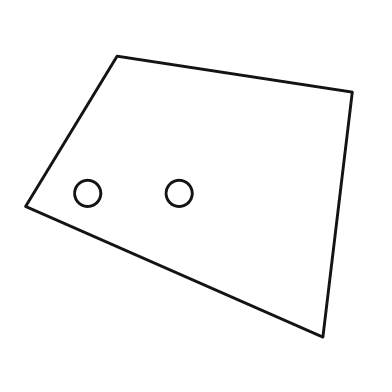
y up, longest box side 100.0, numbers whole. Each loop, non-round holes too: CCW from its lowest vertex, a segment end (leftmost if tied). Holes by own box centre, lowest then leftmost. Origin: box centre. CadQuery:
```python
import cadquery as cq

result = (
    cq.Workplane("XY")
    .moveTo(41.0, -43.0)
    .lineTo(50.0, 32.0)
    .lineTo(-22.0, 43.0)
    .lineTo(-50.0, -3.0)
    .close()
    .moveTo(-31.0, 1.0)
    .circle(4.0)
    .moveTo(-3.0, 1.0)
    .circle(4.0)
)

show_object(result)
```